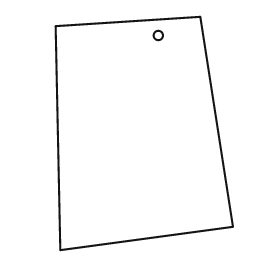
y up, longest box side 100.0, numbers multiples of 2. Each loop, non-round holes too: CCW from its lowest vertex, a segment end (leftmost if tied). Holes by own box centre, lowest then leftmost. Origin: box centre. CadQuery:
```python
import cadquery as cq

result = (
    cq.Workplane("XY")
    .moveTo(-36.0, -50.0)
    .lineTo(38.0, -40.0)
    .lineTo(24.0, 50.0)
    .lineTo(-38.0, 46.0)
    .close()
    .moveTo(6.0, 42.0)
    .circle(2.0)
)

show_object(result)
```